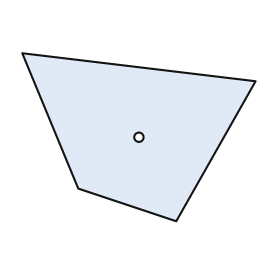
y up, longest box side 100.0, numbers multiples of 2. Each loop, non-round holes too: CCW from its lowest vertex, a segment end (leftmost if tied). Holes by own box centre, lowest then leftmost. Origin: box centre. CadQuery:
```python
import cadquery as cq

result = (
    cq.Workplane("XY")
    .moveTo(16.0, -36.0)
    .lineTo(50.0, 24.0)
    .lineTo(-50.0, 36.0)
    .lineTo(-26.0, -22.0)
    .close()
    .moveTo(0.0, 0.0)
    .circle(2.0)
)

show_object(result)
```